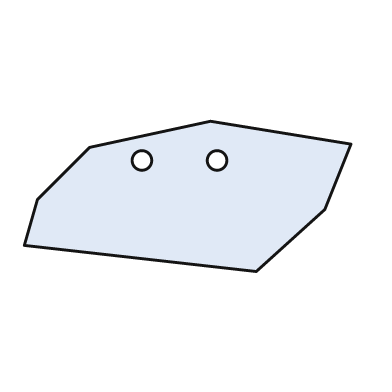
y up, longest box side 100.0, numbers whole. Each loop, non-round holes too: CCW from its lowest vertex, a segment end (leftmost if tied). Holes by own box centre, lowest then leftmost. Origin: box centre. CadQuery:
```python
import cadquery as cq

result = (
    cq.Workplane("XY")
    .moveTo(21.0, -23.0)
    .lineTo(42.0, -4.0)
    .lineTo(50.0, 16.0)
    .lineTo(7.0, 23.0)
    .lineTo(-30.0, 15.0)
    .lineTo(-46.0, -1.0)
    .lineTo(-50.0, -15.0)
    .close()
    .moveTo(-14.0, 11.0)
    .circle(3.0)
    .moveTo(9.0, 11.0)
    .circle(3.0)
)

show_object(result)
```